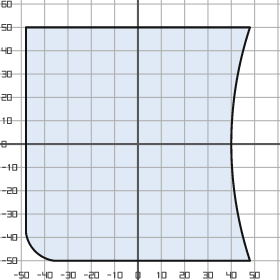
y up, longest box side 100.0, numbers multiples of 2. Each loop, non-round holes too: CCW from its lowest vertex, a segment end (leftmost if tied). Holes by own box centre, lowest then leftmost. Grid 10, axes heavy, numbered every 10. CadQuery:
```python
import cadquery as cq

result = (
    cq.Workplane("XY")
    .moveTo(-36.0, -50.0)
    .lineTo(48.0, -50.0)
    .threePointArc((40.0, 0.0), (48.0, 50.0))
    .lineTo(-48.0, 50.0)
    .lineTo(-48.0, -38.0)
    .threePointArc((-44.0, -46.0), (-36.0, -50.0))
    .close()
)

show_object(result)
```